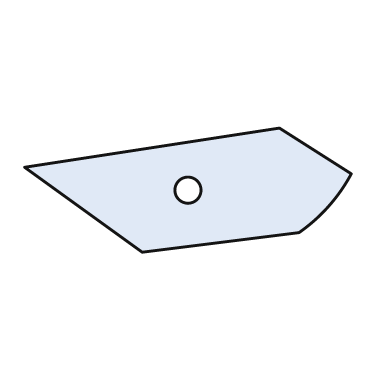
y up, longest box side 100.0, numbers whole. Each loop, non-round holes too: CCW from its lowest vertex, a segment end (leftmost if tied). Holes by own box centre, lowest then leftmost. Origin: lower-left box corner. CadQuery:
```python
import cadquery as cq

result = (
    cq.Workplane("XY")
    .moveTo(36.0, 0.0)
    .lineTo(84.0, 6.0)
    .threePointArc((93.0, 14.0), (100.0, 24.0))
    .lineTo(78.0, 38.0)
    .lineTo(0.0, 26.0)
    .close()
    .moveTo(50.0, 19.0)
    .circle(4.0)
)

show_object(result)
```